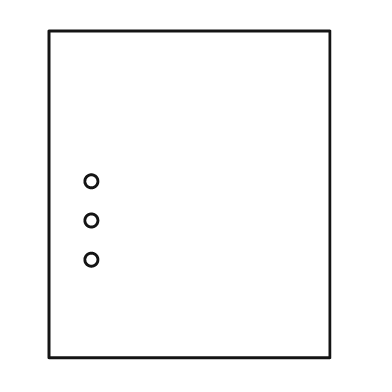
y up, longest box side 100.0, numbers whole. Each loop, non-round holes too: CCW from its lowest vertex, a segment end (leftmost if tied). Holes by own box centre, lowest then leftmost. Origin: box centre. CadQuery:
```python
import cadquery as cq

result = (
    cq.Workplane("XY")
    .moveTo(-43.0, -50.0)
    .lineTo(43.0, -50.0)
    .lineTo(43.0, 50.0)
    .lineTo(-43.0, 50.0)
    .close()
    .moveTo(-30.0, -20.0)
    .circle(2.0)
    .moveTo(-30.0, -8.0)
    .circle(2.0)
    .moveTo(-30.0, 4.0)
    .circle(2.0)
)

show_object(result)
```